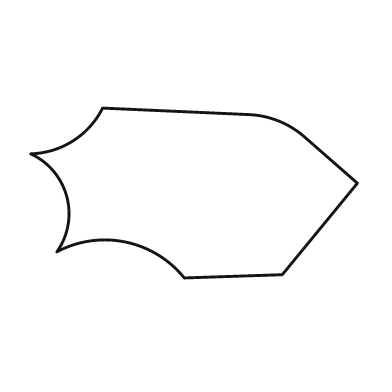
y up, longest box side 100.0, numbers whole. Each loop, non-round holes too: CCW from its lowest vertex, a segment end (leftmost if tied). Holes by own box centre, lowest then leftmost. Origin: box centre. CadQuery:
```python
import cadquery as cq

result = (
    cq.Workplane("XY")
    .moveTo(-3.0, -26.0)
    .lineTo(27.0, -25.0)
    .lineTo(50.0, 3.0)
    .lineTo(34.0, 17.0)
    .threePointArc((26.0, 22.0), (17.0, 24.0))
    .lineTo(-28.0, 26.0)
    .threePointArc((-37.0, 16.0), (-50.0, 12.0))
    .threePointArc((-39.0, -1.0), (-42.0, -18.0))
    .threePointArc((-21.0, -15.0), (-3.0, -26.0))
    .close()
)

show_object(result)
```